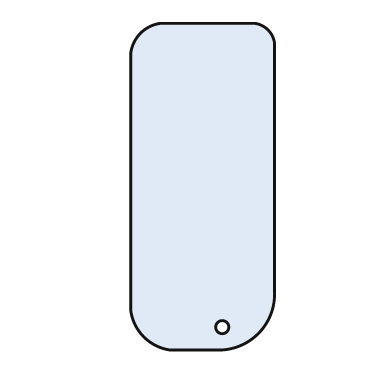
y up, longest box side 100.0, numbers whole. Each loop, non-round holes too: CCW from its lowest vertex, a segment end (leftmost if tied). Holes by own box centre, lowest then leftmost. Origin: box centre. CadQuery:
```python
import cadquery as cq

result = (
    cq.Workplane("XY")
    .moveTo(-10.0, -50.0)
    .lineTo(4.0, -50.0)
    .threePointArc((17.0, -45.0), (22.0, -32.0))
    .lineTo(22.0, 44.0)
    .threePointArc((20.0, 48.0), (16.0, 50.0))
    .lineTo(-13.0, 50.0)
    .threePointArc((-19.0, 47.0), (-22.0, 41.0))
    .lineTo(-22.0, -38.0)
    .threePointArc((-18.0, -46.0), (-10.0, -50.0))
    .close()
    .moveTo(6.0, -43.0)
    .circle(2.0)
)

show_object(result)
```